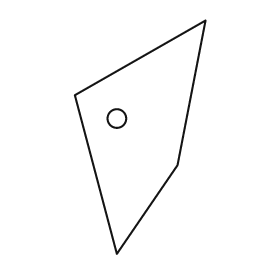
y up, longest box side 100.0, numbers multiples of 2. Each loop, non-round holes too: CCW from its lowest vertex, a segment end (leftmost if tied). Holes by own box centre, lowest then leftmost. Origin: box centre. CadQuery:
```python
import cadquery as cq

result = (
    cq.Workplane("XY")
    .moveTo(-10.0, -50.0)
    .lineTo(16.0, -12.0)
    .lineTo(28.0, 50.0)
    .lineTo(-28.0, 18.0)
    .close()
    .moveTo(-10.0, 8.0)
    .circle(4.0)
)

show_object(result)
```